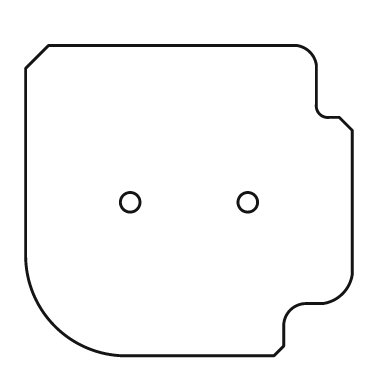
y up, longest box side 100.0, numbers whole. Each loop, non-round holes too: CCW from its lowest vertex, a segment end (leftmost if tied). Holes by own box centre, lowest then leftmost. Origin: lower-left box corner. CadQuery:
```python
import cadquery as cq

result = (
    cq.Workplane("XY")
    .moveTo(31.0, 0.0)
    .lineTo(76.0, 0.0)
    .lineTo(79.0, 3.0)
    .lineTo(79.0, 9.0)
    .threePointArc((81.0, 14.0), (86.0, 16.0))
    .lineTo(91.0, 16.0)
    .threePointArc((97.0, 19.0), (100.0, 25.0))
    .lineTo(100.0, 69.0)
    .lineTo(96.0, 73.0)
    .lineTo(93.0, 73.0)
    .threePointArc((90.0, 74.0), (89.0, 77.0))
    .lineTo(89.0, 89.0)
    .threePointArc((87.0, 93.0), (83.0, 95.0))
    .lineTo(7.0, 95.0)
    .lineTo(0.0, 88.0)
    .lineTo(0.0, 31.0)
    .threePointArc((9.0, 9.0), (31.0, 0.0))
    .close()
    .moveTo(32.0, 47.0)
    .circle(3.0)
    .moveTo(68.0, 47.0)
    .circle(3.0)
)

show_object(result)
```